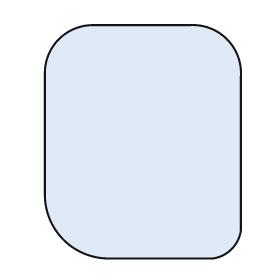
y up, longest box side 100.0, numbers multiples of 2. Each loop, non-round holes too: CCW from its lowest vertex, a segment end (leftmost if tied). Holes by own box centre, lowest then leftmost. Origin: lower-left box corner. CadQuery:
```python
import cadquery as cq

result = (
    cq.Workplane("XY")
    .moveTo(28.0, 0.0)
    .lineTo(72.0, 0.0)
    .threePointArc((80.0, 4.0), (84.0, 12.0))
    .lineTo(84.0, 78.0)
    .threePointArc((78.0, 94.0), (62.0, 100.0))
    .lineTo(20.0, 100.0)
    .threePointArc((6.0, 94.0), (0.0, 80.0))
    .lineTo(0.0, 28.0)
    .threePointArc((8.0, 8.0), (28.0, 0.0))
    .close()
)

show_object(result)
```